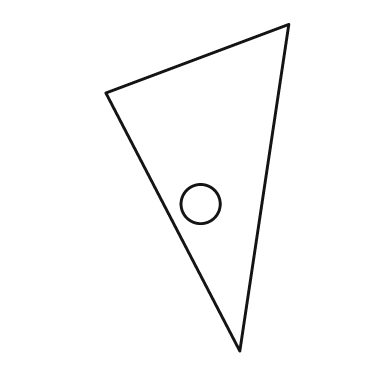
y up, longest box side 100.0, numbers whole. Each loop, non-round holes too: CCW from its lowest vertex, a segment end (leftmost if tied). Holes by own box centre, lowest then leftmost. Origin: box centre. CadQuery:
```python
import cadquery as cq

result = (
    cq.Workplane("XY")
    .moveTo(13.0, -50.0)
    .lineTo(28.0, 50.0)
    .lineTo(-28.0, 29.0)
    .close()
    .moveTo(1.0, -5.0)
    .circle(6.0)
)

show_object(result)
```